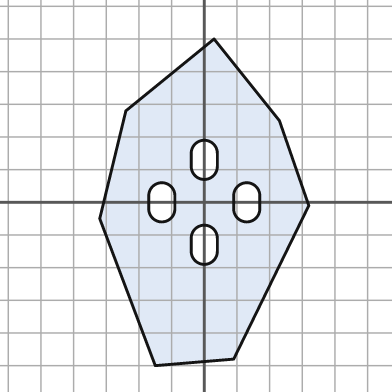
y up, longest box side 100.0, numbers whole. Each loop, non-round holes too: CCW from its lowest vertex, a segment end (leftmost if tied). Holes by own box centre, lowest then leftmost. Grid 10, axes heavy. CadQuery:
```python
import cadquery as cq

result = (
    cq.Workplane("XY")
    .moveTo(-15.0, -50.0)
    .lineTo(9.0, -48.0)
    .lineTo(32.0, -1.0)
    .lineTo(23.0, 25.0)
    .lineTo(3.0, 50.0)
    .lineTo(-24.0, 28.0)
    .lineTo(-32.0, -5.0)
    .close()
    .moveTo(-4.0, -15.0)
    .threePointArc((0.0, -19.0), (4.0, -15.0))
    .lineTo(4.0, -11.0)
    .threePointArc((0.0, -7.0), (-4.0, -11.0))
    .close()
    .moveTo(-17.0, -2.0)
    .threePointArc((-13.0, -6.0), (-9.0, -2.0))
    .lineTo(-9.0, 2.0)
    .threePointArc((-13.0, 6.0), (-17.0, 2.0))
    .close()
    .moveTo(9.0, -2.0)
    .threePointArc((13.0, -6.0), (17.0, -2.0))
    .lineTo(17.0, 2.0)
    .threePointArc((13.0, 6.0), (9.0, 2.0))
    .close()
    .moveTo(-4.0, 11.0)
    .threePointArc((0.0, 7.0), (4.0, 11.0))
    .lineTo(4.0, 15.0)
    .threePointArc((0.0, 19.0), (-4.0, 15.0))
    .close()
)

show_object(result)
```